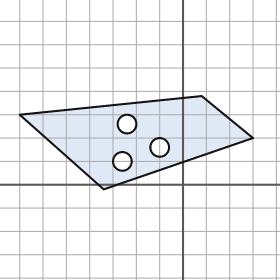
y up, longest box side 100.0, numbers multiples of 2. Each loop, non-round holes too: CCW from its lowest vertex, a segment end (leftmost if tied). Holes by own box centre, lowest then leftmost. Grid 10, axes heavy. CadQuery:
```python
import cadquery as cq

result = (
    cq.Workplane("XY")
    .moveTo(-34.0, -2.0)
    .lineTo(30.0, 20.0)
    .lineTo(8.0, 38.0)
    .lineTo(-70.0, 30.0)
    .close()
    .moveTo(-26.0, 10.0)
    .circle(4.0)
    .moveTo(-10.0, 16.0)
    .circle(4.0)
    .moveTo(-24.0, 26.0)
    .circle(4.0)
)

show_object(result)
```